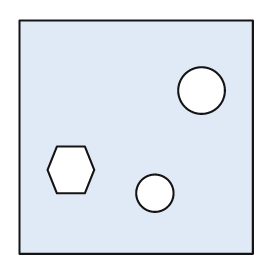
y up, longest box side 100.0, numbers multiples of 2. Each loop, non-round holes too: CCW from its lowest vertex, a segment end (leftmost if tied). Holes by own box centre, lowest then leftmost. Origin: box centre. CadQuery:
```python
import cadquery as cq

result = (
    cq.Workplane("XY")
    .moveTo(-50.0, -50.0)
    .lineTo(50.0, -50.0)
    .lineTo(50.0, 50.0)
    .lineTo(-50.0, 50.0)
    .close()
    .moveTo(8.0, -24.0)
    .circle(8.0)
    .moveTo(-34.0, -24.0)
    .lineTo(-22.0, -24.0)
    .lineTo(-18.0, -14.0)
    .lineTo(-22.0, -4.0)
    .lineTo(-34.0, -4.0)
    .lineTo(-38.0, -14.0)
    .close()
    .moveTo(28.0, 20.0)
    .circle(10.0)
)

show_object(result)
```